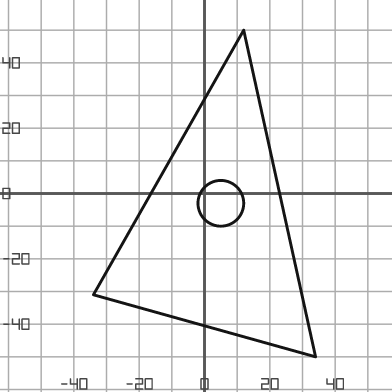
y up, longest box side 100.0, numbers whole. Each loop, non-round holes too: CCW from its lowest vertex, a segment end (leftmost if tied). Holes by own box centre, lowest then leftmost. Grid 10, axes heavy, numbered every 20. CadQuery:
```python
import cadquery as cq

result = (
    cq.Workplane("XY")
    .moveTo(34.0, -50.0)
    .lineTo(12.0, 50.0)
    .lineTo(-34.0, -31.0)
    .close()
    .moveTo(5.0, -3.0)
    .circle(7.0)
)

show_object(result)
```